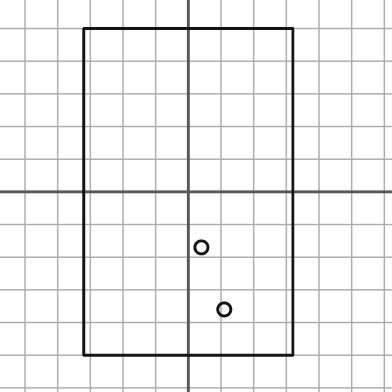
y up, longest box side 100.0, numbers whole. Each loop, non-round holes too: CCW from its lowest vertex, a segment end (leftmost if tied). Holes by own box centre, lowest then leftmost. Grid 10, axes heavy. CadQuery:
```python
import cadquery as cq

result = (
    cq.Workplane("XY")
    .moveTo(-32.0, -50.0)
    .lineTo(32.0, -50.0)
    .lineTo(32.0, 50.0)
    .lineTo(-32.0, 50.0)
    .close()
    .moveTo(11.0, -36.0)
    .circle(2.0)
    .moveTo(4.0, -17.0)
    .circle(2.0)
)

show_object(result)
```